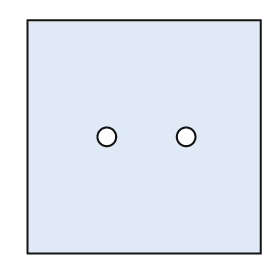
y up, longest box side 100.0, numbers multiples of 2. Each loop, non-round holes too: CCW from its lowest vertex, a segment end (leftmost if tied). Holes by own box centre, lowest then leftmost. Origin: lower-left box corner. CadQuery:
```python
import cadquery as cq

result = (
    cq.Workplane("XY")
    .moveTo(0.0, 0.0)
    .lineTo(100.0, 0.0)
    .lineTo(100.0, 100.0)
    .lineTo(0.0, 100.0)
    .close()
    .moveTo(34.0, 50.0)
    .circle(4.0)
    .moveTo(68.0, 50.0)
    .circle(4.0)
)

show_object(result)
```